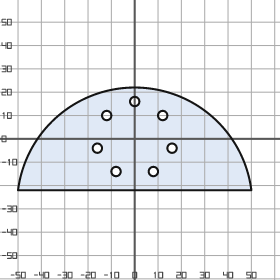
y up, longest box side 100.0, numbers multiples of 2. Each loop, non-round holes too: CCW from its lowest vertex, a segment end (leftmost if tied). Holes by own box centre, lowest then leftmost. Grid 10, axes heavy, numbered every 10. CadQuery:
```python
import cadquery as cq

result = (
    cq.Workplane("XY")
    .moveTo(-50.0, -22.0)
    .lineTo(50.0, -22.0)
    .threePointArc((0.0, 22.0), (-50.0, -22.0))
    .close()
    .moveTo(-8.0, -14.0)
    .circle(2.0)
    .moveTo(8.0, -14.0)
    .circle(2.0)
    .moveTo(-16.0, -4.0)
    .circle(2.0)
    .moveTo(16.0, -4.0)
    .circle(2.0)
    .moveTo(-12.0, 10.0)
    .circle(2.0)
    .moveTo(12.0, 10.0)
    .circle(2.0)
    .moveTo(0.0, 16.0)
    .circle(2.0)
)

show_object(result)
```